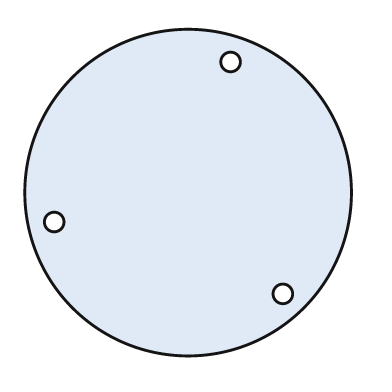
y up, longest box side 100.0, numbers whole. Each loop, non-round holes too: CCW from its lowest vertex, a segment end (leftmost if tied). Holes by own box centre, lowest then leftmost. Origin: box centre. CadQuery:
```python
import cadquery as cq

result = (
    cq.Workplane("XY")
    .moveTo(0.0, 0.0)
    .circle(50.0)
    .moveTo(29.0, -31.0)
    .circle(3.0)
    .moveTo(-41.0, -9.0)
    .circle(3.0)
    .moveTo(13.0, 40.0)
    .circle(3.0)
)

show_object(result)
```